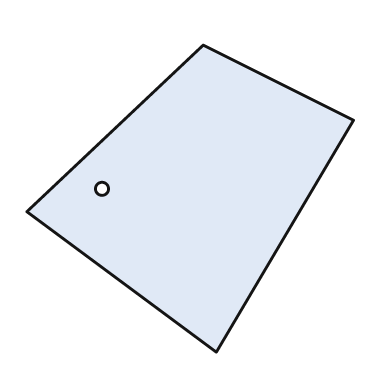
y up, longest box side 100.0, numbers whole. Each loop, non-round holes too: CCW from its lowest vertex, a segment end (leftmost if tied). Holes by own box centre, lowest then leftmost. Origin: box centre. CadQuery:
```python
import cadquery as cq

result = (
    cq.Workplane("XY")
    .moveTo(8.0, -47.0)
    .lineTo(50.0, 24.0)
    .lineTo(4.0, 47.0)
    .lineTo(-50.0, -4.0)
    .close()
    .moveTo(-27.0, 3.0)
    .circle(2.0)
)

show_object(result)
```